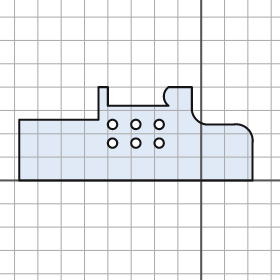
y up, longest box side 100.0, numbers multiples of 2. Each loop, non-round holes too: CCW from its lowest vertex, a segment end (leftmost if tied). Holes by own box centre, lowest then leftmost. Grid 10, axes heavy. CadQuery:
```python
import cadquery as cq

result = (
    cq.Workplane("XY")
    .moveTo(-78.0, 0.0)
    .lineTo(22.0, 0.0)
    .lineTo(22.0, 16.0)
    .threePointArc((20.0, 22.0), (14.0, 24.0))
    .lineTo(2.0, 24.0)
    .threePointArc((-2.0, 26.0), (-4.0, 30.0))
    .lineTo(-4.0, 40.0)
    .lineTo(-14.0, 40.0)
    .threePointArc((-16.0, 36.0), (-14.0, 32.0))
    .lineTo(-40.0, 32.0)
    .lineTo(-40.0, 40.0)
    .lineTo(-44.0, 40.0)
    .lineTo(-44.0, 26.0)
    .lineTo(-78.0, 26.0)
    .close()
    .moveTo(-38.0, 16.0)
    .circle(2.0)
    .moveTo(-28.0, 16.0)
    .circle(2.0)
    .moveTo(-18.0, 16.0)
    .circle(2.0)
    .moveTo(-38.0, 24.0)
    .circle(2.0)
    .moveTo(-28.0, 24.0)
    .circle(2.0)
    .moveTo(-18.0, 24.0)
    .circle(2.0)
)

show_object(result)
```